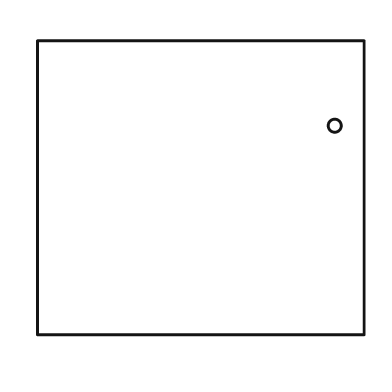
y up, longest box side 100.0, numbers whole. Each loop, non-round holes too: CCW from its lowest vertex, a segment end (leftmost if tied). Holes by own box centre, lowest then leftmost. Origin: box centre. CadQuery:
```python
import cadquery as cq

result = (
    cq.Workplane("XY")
    .moveTo(-50.0, -45.0)
    .lineTo(50.0, -45.0)
    .lineTo(50.0, 45.0)
    .lineTo(-50.0, 45.0)
    .close()
    .moveTo(41.0, 19.0)
    .circle(2.0)
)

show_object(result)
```